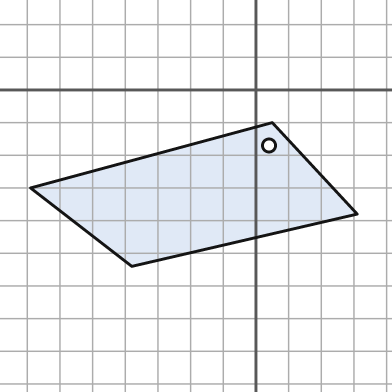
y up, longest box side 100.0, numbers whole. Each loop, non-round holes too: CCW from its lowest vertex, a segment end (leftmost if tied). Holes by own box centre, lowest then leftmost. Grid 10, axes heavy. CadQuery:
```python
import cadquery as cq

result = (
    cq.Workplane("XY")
    .moveTo(-38.0, -54.0)
    .lineTo(31.0, -38.0)
    .lineTo(5.0, -10.0)
    .lineTo(-69.0, -30.0)
    .close()
    .moveTo(4.0, -17.0)
    .circle(2.0)
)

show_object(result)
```